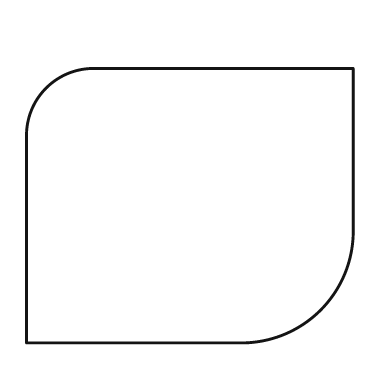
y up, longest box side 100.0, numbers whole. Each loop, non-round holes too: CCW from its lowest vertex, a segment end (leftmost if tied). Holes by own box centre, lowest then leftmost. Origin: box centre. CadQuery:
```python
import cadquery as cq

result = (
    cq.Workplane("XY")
    .moveTo(-50.0, -42.0)
    .lineTo(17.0, -42.0)
    .threePointArc((40.0, -32.0), (50.0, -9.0))
    .lineTo(50.0, 42.0)
    .lineTo(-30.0, 42.0)
    .threePointArc((-44.0, 36.0), (-50.0, 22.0))
    .close()
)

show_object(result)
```